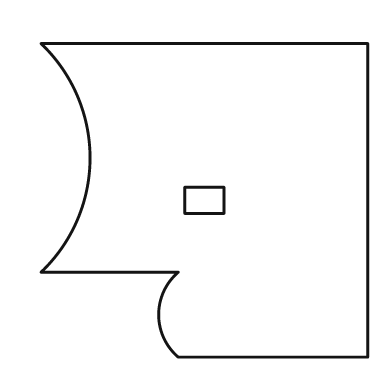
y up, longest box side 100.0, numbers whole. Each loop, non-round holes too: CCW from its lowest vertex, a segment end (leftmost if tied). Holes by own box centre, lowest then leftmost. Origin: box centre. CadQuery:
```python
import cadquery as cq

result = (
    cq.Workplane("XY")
    .moveTo(-8.0, -48.0)
    .lineTo(50.0, -48.0)
    .lineTo(50.0, 48.0)
    .lineTo(-50.0, 48.0)
    .threePointArc((-35.0, 13.0), (-50.0, -22.0))
    .lineTo(-8.0, -22.0)
    .threePointArc((-14.0, -35.0), (-8.0, -48.0))
    .close()
    .moveTo(-6.0, -4.0)
    .lineTo(6.0, -4.0)
    .lineTo(6.0, 4.0)
    .lineTo(-6.0, 4.0)
    .close()
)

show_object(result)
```